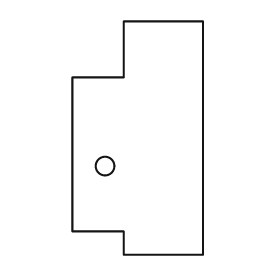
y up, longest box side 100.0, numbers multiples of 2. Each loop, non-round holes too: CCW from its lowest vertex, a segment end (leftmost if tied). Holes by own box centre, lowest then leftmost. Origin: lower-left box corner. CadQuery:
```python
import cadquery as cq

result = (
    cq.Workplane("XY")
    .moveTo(22.0, 0.0)
    .lineTo(56.0, 0.0)
    .lineTo(56.0, 100.0)
    .lineTo(22.0, 100.0)
    .lineTo(22.0, 76.0)
    .lineTo(0.0, 76.0)
    .lineTo(0.0, 10.0)
    .lineTo(22.0, 10.0)
    .close()
    .moveTo(14.0, 38.0)
    .circle(4.0)
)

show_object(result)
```